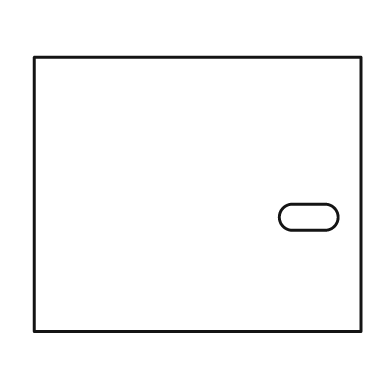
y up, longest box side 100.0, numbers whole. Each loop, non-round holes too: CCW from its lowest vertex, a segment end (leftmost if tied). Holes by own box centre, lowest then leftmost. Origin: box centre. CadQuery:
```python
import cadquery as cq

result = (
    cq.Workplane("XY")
    .moveTo(-50.0, -42.0)
    .lineTo(50.0, -42.0)
    .lineTo(50.0, 42.0)
    .lineTo(-50.0, 42.0)
    .close()
    .moveTo(29.0, -11.0)
    .lineTo(39.0, -11.0)
    .threePointArc((43.0, -7.0), (39.0, -3.0))
    .lineTo(29.0, -3.0)
    .threePointArc((25.0, -7.0), (29.0, -11.0))
    .close()
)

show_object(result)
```